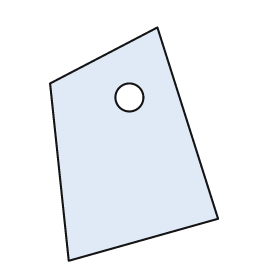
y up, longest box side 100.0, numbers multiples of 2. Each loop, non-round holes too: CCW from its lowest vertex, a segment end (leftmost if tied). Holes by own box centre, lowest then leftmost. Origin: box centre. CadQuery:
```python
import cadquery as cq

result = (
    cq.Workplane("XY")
    .moveTo(-28.0, -50.0)
    .lineTo(36.0, -32.0)
    .lineTo(10.0, 50.0)
    .lineTo(-36.0, 26.0)
    .close()
    .moveTo(-2.0, 20.0)
    .circle(6.0)
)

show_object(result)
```